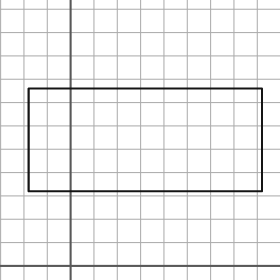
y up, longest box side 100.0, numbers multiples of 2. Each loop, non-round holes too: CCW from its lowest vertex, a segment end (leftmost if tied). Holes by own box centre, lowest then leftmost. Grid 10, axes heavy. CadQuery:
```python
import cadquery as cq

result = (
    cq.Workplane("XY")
    .moveTo(-18.0, 32.0)
    .lineTo(82.0, 32.0)
    .lineTo(82.0, 76.0)
    .lineTo(-18.0, 76.0)
    .close()
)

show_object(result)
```